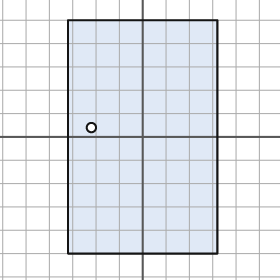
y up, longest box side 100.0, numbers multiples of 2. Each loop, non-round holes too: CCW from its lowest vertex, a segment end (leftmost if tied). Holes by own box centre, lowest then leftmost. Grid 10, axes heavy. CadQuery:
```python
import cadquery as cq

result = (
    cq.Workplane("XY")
    .moveTo(-32.0, -50.0)
    .lineTo(32.0, -50.0)
    .lineTo(32.0, 50.0)
    .lineTo(-32.0, 50.0)
    .close()
    .moveTo(-22.0, 4.0)
    .circle(2.0)
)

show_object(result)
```